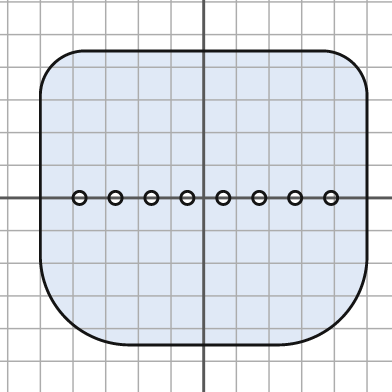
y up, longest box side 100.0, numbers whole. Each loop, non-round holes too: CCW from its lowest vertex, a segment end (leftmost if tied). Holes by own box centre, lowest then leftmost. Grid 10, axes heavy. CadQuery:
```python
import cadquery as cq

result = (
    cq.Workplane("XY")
    .moveTo(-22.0, -45.0)
    .lineTo(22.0, -45.0)
    .threePointArc((42.0, -37.0), (50.0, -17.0))
    .lineTo(50.0, 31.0)
    .threePointArc((46.0, 41.0), (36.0, 45.0))
    .lineTo(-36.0, 45.0)
    .threePointArc((-46.0, 41.0), (-50.0, 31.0))
    .lineTo(-50.0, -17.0)
    .threePointArc((-42.0, -37.0), (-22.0, -45.0))
    .close()
    .moveTo(-38.0, 0.0)
    .circle(2.0)
    .moveTo(-27.0, 0.0)
    .circle(2.0)
    .moveTo(-16.0, 0.0)
    .circle(2.0)
    .moveTo(-5.0, 0.0)
    .circle(2.0)
    .moveTo(6.0, 0.0)
    .circle(2.0)
    .moveTo(17.0, 0.0)
    .circle(2.0)
    .moveTo(28.0, 0.0)
    .circle(2.0)
    .moveTo(39.0, 0.0)
    .circle(2.0)
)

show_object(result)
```